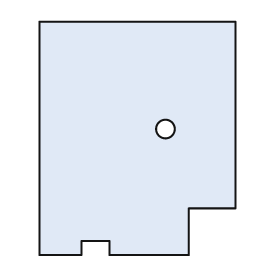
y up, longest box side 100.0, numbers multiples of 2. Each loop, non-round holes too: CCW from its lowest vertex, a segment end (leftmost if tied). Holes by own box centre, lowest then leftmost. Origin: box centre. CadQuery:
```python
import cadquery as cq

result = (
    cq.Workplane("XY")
    .moveTo(-42.0, -50.0)
    .lineTo(-24.0, -50.0)
    .lineTo(-24.0, -44.0)
    .lineTo(-12.0, -44.0)
    .lineTo(-12.0, -50.0)
    .lineTo(22.0, -50.0)
    .lineTo(22.0, -30.0)
    .lineTo(42.0, -30.0)
    .lineTo(42.0, 50.0)
    .lineTo(-42.0, 50.0)
    .close()
    .moveTo(12.0, 4.0)
    .circle(4.0)
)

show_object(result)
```